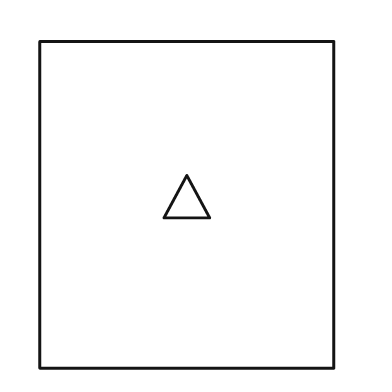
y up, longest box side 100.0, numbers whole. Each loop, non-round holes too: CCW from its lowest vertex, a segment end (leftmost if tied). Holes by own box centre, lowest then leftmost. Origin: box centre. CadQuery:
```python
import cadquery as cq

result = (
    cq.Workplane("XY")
    .moveTo(-45.0, -50.0)
    .lineTo(45.0, -50.0)
    .lineTo(45.0, 50.0)
    .lineTo(-45.0, 50.0)
    .close()
    .moveTo(-7.0, -4.0)
    .lineTo(7.0, -4.0)
    .lineTo(0.0, 9.0)
    .close()
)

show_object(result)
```